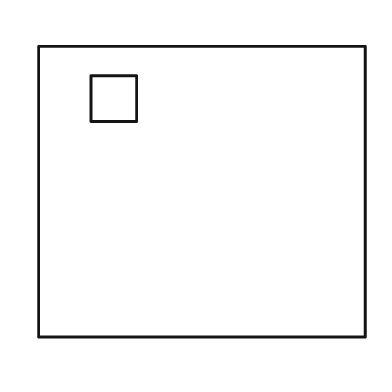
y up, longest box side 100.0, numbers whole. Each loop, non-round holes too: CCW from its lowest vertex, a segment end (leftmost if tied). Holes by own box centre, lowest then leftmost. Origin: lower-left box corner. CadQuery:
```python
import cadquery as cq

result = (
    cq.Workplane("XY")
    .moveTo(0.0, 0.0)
    .lineTo(100.0, 0.0)
    .lineTo(100.0, 89.0)
    .lineTo(0.0, 89.0)
    .close()
    .moveTo(16.0, 66.0)
    .lineTo(30.0, 66.0)
    .lineTo(30.0, 80.0)
    .lineTo(16.0, 80.0)
    .close()
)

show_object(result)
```